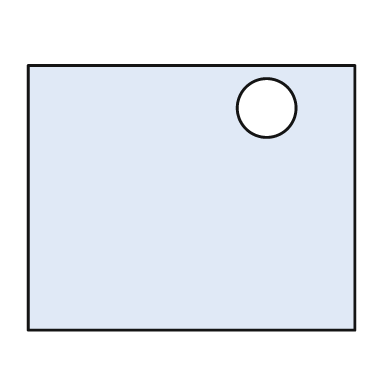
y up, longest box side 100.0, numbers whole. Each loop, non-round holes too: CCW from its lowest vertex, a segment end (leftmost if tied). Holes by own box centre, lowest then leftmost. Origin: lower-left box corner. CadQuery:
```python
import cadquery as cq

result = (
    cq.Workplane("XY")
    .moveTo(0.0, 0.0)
    .lineTo(100.0, 0.0)
    .lineTo(100.0, 81.0)
    .lineTo(0.0, 81.0)
    .close()
    .moveTo(73.0, 68.0)
    .circle(9.0)
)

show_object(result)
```